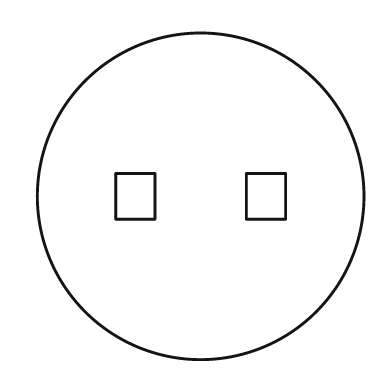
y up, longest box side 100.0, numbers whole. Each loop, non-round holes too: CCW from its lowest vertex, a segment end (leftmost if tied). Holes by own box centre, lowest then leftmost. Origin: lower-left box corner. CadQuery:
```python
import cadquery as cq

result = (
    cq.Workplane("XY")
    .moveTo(50.0, 50.0)
    .circle(50.0)
    .moveTo(24.0, 43.0)
    .lineTo(36.0, 43.0)
    .lineTo(36.0, 57.0)
    .lineTo(24.0, 57.0)
    .close()
    .moveTo(64.0, 43.0)
    .lineTo(76.0, 43.0)
    .lineTo(76.0, 57.0)
    .lineTo(64.0, 57.0)
    .close()
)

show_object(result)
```